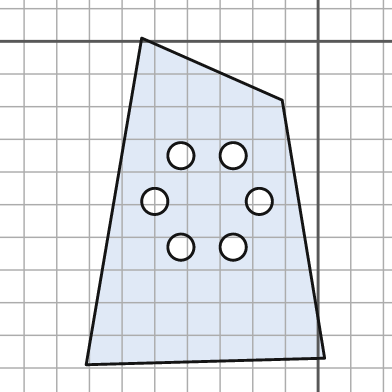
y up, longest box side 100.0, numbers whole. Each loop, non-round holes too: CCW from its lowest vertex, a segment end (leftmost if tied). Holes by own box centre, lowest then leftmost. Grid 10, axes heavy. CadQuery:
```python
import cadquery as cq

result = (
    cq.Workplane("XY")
    .moveTo(-71.0, -99.0)
    .lineTo(2.0, -97.0)
    .lineTo(-11.0, -18.0)
    .lineTo(-54.0, 1.0)
    .close()
    .moveTo(-42.0, -63.0)
    .circle(4.0)
    .moveTo(-26.0, -63.0)
    .circle(4.0)
    .moveTo(-50.0, -49.0)
    .circle(4.0)
    .moveTo(-18.0, -49.0)
    .circle(4.0)
    .moveTo(-42.0, -35.0)
    .circle(4.0)
    .moveTo(-26.0, -35.0)
    .circle(4.0)
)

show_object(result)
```